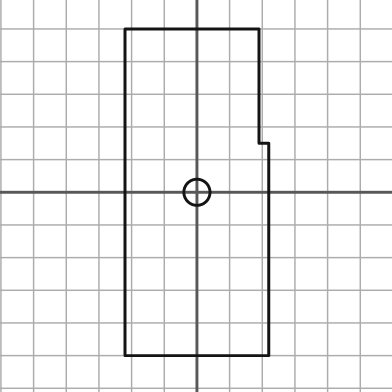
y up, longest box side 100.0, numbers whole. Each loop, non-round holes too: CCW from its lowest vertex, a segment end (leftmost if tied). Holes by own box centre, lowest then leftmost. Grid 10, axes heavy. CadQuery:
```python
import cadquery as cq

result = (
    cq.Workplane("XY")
    .moveTo(-22.0, -50.0)
    .lineTo(22.0, -50.0)
    .lineTo(22.0, 15.0)
    .lineTo(19.0, 15.0)
    .lineTo(19.0, 50.0)
    .lineTo(-22.0, 50.0)
    .close()
    .moveTo(0.0, 0.0)
    .circle(4.0)
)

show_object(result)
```